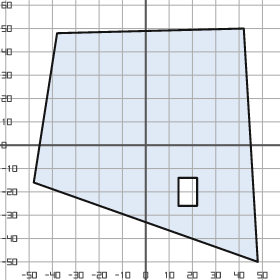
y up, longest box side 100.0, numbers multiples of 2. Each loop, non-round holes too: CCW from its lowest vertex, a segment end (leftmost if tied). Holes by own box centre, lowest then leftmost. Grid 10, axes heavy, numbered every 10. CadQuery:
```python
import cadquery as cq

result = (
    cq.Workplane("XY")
    .moveTo(48.0, -50.0)
    .lineTo(42.0, 50.0)
    .lineTo(-38.0, 48.0)
    .lineTo(-48.0, -16.0)
    .close()
    .moveTo(14.0, -26.0)
    .lineTo(22.0, -26.0)
    .lineTo(22.0, -14.0)
    .lineTo(14.0, -14.0)
    .close()
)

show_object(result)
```